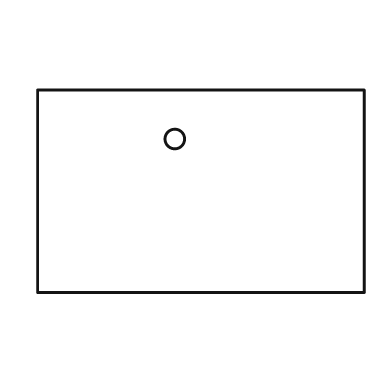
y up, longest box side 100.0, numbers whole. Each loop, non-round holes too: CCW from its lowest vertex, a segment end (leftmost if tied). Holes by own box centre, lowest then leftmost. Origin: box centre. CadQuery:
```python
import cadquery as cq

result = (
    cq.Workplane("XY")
    .moveTo(-50.0, -31.0)
    .lineTo(50.0, -31.0)
    .lineTo(50.0, 31.0)
    .lineTo(-50.0, 31.0)
    .close()
    .moveTo(-8.0, 16.0)
    .circle(3.0)
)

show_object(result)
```